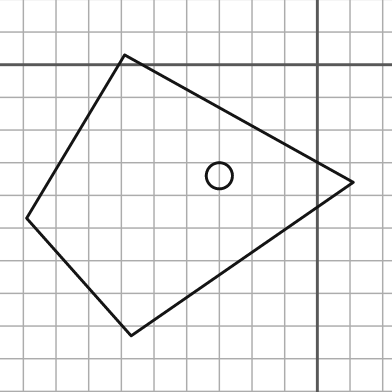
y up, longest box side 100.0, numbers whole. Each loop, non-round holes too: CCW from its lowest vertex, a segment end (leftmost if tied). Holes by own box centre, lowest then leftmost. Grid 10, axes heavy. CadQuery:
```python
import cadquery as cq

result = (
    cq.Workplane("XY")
    .moveTo(-57.0, -83.0)
    .lineTo(11.0, -36.0)
    .lineTo(-59.0, 3.0)
    .lineTo(-89.0, -47.0)
    .close()
    .moveTo(-30.0, -34.0)
    .circle(4.0)
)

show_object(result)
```